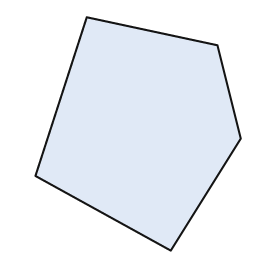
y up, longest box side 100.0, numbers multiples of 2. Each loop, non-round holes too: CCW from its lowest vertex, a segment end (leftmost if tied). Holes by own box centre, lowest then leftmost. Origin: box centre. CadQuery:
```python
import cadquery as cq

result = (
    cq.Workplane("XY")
    .moveTo(14.0, -50.0)
    .lineTo(44.0, -2.0)
    .lineTo(34.0, 38.0)
    .lineTo(-22.0, 50.0)
    .lineTo(-44.0, -18.0)
    .close()
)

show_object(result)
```